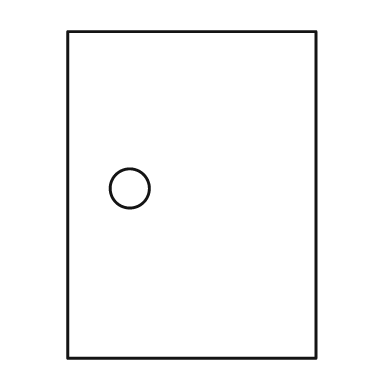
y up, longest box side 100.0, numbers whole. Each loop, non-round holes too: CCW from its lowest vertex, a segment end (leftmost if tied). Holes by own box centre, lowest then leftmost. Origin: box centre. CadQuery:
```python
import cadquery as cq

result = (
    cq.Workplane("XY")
    .moveTo(-38.0, -50.0)
    .lineTo(38.0, -50.0)
    .lineTo(38.0, 50.0)
    .lineTo(-38.0, 50.0)
    .close()
    .moveTo(-19.0, 2.0)
    .circle(6.0)
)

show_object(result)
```